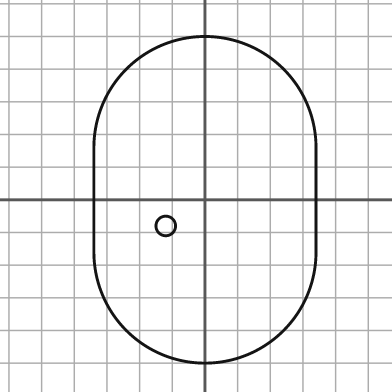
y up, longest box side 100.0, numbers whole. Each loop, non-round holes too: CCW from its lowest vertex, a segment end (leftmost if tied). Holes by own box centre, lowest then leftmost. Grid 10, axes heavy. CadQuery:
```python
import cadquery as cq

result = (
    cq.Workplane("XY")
    .moveTo(-34.0, -16.0)
    .threePointArc((0.0, -50.0), (34.0, -16.0))
    .lineTo(34.0, 16.0)
    .threePointArc((0.0, 50.0), (-34.0, 16.0))
    .close()
    .moveTo(-12.0, -8.0)
    .circle(3.0)
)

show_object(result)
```